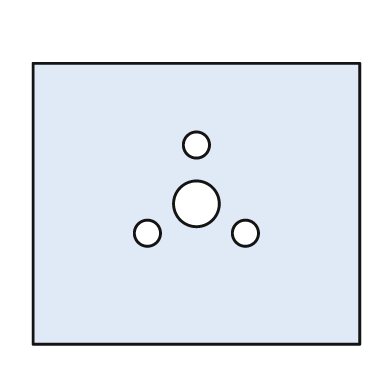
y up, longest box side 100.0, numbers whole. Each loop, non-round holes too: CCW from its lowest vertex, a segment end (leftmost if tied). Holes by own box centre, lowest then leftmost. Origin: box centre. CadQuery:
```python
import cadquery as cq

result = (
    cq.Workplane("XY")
    .moveTo(-50.0, -43.0)
    .lineTo(50.0, -43.0)
    .lineTo(50.0, 43.0)
    .lineTo(-50.0, 43.0)
    .close()
    .moveTo(-15.0, -9.0)
    .circle(4.0)
    .moveTo(15.0, -9.0)
    .circle(4.0)
    .moveTo(0.0, 0.0)
    .circle(7.0)
    .moveTo(0.0, 18.0)
    .circle(4.0)
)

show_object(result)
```